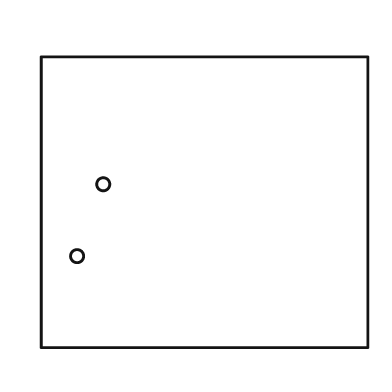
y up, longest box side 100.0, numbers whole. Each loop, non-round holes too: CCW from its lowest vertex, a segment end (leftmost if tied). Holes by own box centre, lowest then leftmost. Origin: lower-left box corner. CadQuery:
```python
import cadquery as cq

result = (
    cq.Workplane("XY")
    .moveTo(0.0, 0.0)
    .lineTo(100.0, 0.0)
    .lineTo(100.0, 89.0)
    .lineTo(0.0, 89.0)
    .close()
    .moveTo(11.0, 28.0)
    .circle(2.0)
    .moveTo(19.0, 50.0)
    .circle(2.0)
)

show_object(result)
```